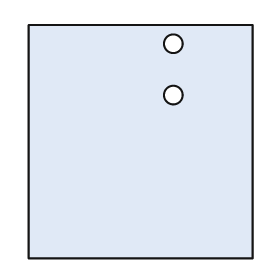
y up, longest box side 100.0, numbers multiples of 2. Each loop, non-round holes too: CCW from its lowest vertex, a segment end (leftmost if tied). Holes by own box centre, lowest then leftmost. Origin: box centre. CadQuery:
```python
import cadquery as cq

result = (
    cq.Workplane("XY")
    .moveTo(-48.0, -50.0)
    .lineTo(48.0, -50.0)
    .lineTo(48.0, 50.0)
    .lineTo(-48.0, 50.0)
    .close()
    .moveTo(14.0, 20.0)
    .circle(4.0)
    .moveTo(14.0, 42.0)
    .circle(4.0)
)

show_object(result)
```